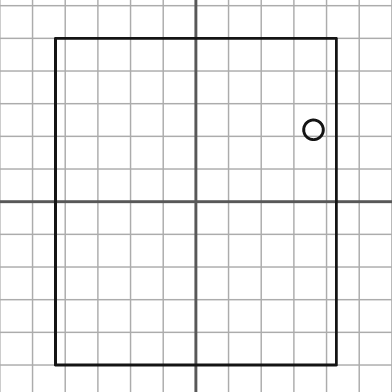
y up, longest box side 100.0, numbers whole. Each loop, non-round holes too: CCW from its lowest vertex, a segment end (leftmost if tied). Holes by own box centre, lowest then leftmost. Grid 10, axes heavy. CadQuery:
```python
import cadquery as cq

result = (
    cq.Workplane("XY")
    .moveTo(-43.0, -50.0)
    .lineTo(43.0, -50.0)
    .lineTo(43.0, 50.0)
    .lineTo(-43.0, 50.0)
    .close()
    .moveTo(36.0, 22.0)
    .circle(3.0)
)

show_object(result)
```